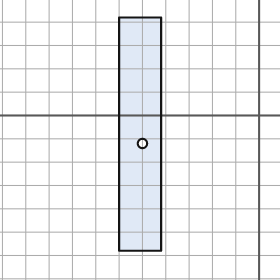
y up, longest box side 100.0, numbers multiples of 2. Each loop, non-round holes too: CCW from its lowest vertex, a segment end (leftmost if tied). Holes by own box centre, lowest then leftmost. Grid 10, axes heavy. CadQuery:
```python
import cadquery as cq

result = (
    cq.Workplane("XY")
    .moveTo(-60.0, -58.0)
    .lineTo(-42.0, -58.0)
    .lineTo(-42.0, 42.0)
    .lineTo(-60.0, 42.0)
    .close()
    .moveTo(-50.0, -12.0)
    .circle(2.0)
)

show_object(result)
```